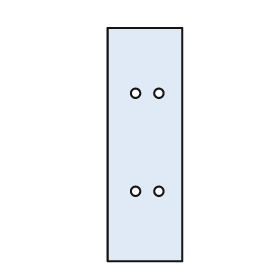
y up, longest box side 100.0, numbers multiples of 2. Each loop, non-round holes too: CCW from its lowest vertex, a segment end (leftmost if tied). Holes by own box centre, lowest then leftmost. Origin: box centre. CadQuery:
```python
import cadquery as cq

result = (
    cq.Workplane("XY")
    .moveTo(-16.0, -50.0)
    .lineTo(16.0, -50.0)
    .lineTo(16.0, 50.0)
    .lineTo(-16.0, 50.0)
    .close()
    .moveTo(-4.0, -20.0)
    .circle(2.0)
    .moveTo(6.0, -20.0)
    .circle(2.0)
    .moveTo(-4.0, 22.0)
    .circle(2.0)
    .moveTo(6.0, 22.0)
    .circle(2.0)
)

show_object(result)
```